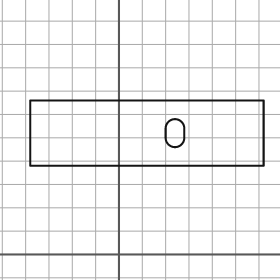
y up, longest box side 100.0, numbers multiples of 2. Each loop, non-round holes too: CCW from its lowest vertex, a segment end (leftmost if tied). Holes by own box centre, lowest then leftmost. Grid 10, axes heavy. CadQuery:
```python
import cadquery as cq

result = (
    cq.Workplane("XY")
    .moveTo(-38.0, 38.0)
    .lineTo(62.0, 38.0)
    .lineTo(62.0, 66.0)
    .lineTo(-38.0, 66.0)
    .close()
    .moveTo(20.0, 50.0)
    .threePointArc((24.0, 46.0), (28.0, 50.0))
    .lineTo(28.0, 54.0)
    .threePointArc((24.0, 58.0), (20.0, 54.0))
    .close()
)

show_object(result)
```